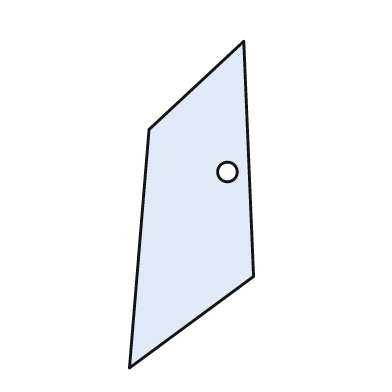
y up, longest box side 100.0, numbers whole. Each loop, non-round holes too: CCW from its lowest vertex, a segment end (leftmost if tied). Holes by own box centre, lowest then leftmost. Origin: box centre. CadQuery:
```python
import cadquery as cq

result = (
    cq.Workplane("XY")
    .moveTo(-19.0, -50.0)
    .lineTo(19.0, -22.0)
    .lineTo(16.0, 50.0)
    .lineTo(-13.0, 23.0)
    .close()
    .moveTo(11.0, 10.0)
    .circle(3.0)
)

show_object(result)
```